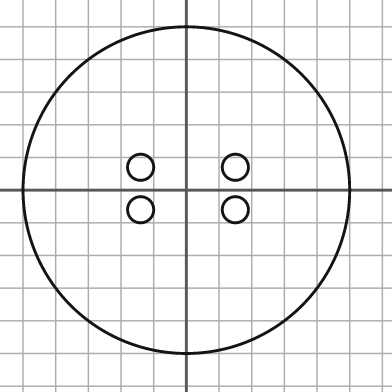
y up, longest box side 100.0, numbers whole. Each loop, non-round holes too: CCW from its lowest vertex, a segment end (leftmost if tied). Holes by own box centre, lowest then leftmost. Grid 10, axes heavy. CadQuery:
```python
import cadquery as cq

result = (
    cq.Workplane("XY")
    .moveTo(0.0, 0.0)
    .circle(50.0)
    .moveTo(-14.0, -6.0)
    .circle(4.0)
    .moveTo(15.0, -6.0)
    .circle(4.0)
    .moveTo(-14.0, 7.0)
    .circle(4.0)
    .moveTo(15.0, 7.0)
    .circle(4.0)
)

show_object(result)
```